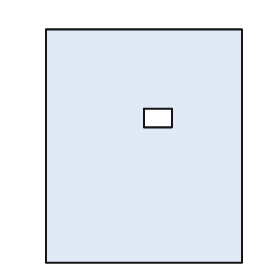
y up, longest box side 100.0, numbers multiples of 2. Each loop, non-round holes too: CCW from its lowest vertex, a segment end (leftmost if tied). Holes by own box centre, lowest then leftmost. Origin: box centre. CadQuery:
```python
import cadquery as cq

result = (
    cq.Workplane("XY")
    .moveTo(-42.0, -50.0)
    .lineTo(42.0, -50.0)
    .lineTo(42.0, 50.0)
    .lineTo(-42.0, 50.0)
    .close()
    .moveTo(0.0, 8.0)
    .lineTo(12.0, 8.0)
    .lineTo(12.0, 16.0)
    .lineTo(0.0, 16.0)
    .close()
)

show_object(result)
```